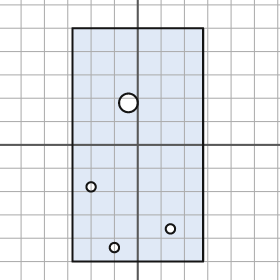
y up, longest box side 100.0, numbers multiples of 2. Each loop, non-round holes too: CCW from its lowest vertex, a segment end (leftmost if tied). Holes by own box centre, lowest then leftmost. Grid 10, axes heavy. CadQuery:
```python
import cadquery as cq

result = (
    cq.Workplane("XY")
    .moveTo(-28.0, -50.0)
    .lineTo(28.0, -50.0)
    .lineTo(28.0, 50.0)
    .lineTo(-28.0, 50.0)
    .close()
    .moveTo(-10.0, -44.0)
    .circle(2.0)
    .moveTo(14.0, -36.0)
    .circle(2.0)
    .moveTo(-20.0, -18.0)
    .circle(2.0)
    .moveTo(-4.0, 18.0)
    .circle(4.0)
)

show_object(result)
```